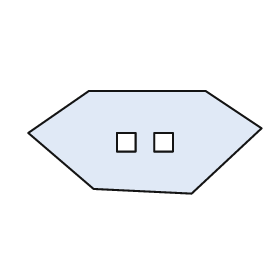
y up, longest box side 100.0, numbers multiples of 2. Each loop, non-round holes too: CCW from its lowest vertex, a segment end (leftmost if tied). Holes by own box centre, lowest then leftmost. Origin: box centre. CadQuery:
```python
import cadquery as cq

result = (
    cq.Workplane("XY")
    .moveTo(20.0, -22.0)
    .lineTo(50.0, 6.0)
    .lineTo(26.0, 22.0)
    .lineTo(-24.0, 22.0)
    .lineTo(-50.0, 4.0)
    .lineTo(-22.0, -20.0)
    .close()
    .moveTo(-12.0, -4.0)
    .lineTo(-4.0, -4.0)
    .lineTo(-4.0, 4.0)
    .lineTo(-12.0, 4.0)
    .close()
    .moveTo(4.0, -4.0)
    .lineTo(12.0, -4.0)
    .lineTo(12.0, 4.0)
    .lineTo(4.0, 4.0)
    .close()
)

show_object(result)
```